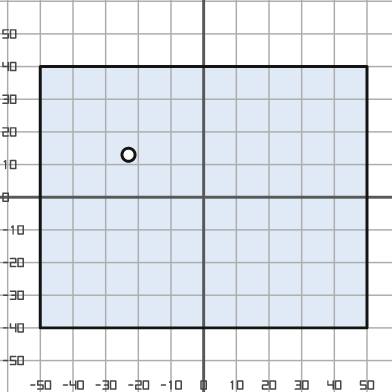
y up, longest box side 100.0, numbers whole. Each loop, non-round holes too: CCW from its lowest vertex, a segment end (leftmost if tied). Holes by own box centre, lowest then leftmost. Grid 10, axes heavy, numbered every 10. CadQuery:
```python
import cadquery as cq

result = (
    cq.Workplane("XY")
    .moveTo(-50.0, -40.0)
    .lineTo(50.0, -40.0)
    .lineTo(50.0, 40.0)
    .lineTo(-50.0, 40.0)
    .close()
    .moveTo(-23.0, 13.0)
    .circle(2.0)
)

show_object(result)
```